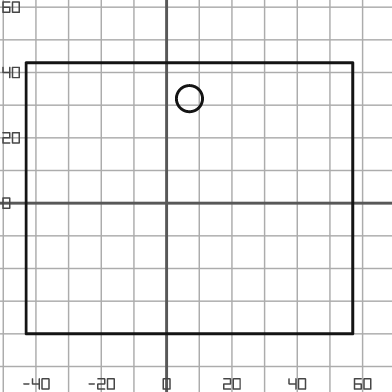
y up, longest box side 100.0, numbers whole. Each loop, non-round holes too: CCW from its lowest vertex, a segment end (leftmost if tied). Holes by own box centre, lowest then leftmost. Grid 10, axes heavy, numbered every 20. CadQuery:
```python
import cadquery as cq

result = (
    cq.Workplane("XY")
    .moveTo(-43.0, -40.0)
    .lineTo(57.0, -40.0)
    .lineTo(57.0, 43.0)
    .lineTo(-43.0, 43.0)
    .close()
    .moveTo(7.0, 32.0)
    .circle(4.0)
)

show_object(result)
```